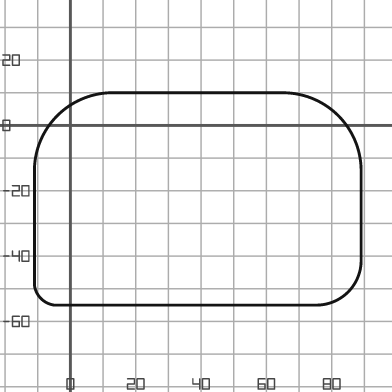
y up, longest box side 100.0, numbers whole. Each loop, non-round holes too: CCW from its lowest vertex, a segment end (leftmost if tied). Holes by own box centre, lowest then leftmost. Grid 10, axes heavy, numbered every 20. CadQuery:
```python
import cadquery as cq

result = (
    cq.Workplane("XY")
    .moveTo(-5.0, -55.0)
    .lineTo(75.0, -55.0)
    .threePointArc((85.0, -51.0), (89.0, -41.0))
    .lineTo(89.0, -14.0)
    .threePointArc((82.0, 3.0), (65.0, 10.0))
    .lineTo(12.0, 10.0)
    .threePointArc((-4.0, 3.0), (-11.0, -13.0))
    .lineTo(-11.0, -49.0)
    .threePointArc((-9.0, -53.0), (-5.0, -55.0))
    .close()
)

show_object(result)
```